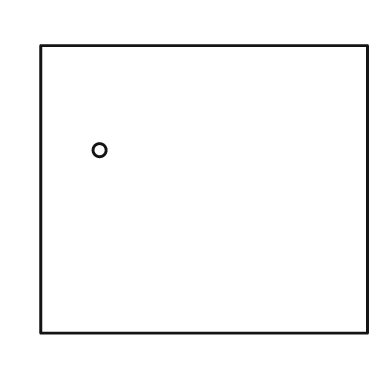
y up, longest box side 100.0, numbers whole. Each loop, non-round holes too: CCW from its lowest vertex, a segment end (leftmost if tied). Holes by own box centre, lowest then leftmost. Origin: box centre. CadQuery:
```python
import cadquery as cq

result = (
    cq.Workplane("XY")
    .moveTo(-50.0, -44.0)
    .lineTo(50.0, -44.0)
    .lineTo(50.0, 44.0)
    .lineTo(-50.0, 44.0)
    .close()
    .moveTo(-32.0, 12.0)
    .circle(2.0)
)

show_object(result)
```